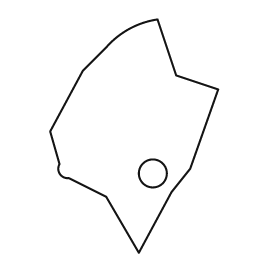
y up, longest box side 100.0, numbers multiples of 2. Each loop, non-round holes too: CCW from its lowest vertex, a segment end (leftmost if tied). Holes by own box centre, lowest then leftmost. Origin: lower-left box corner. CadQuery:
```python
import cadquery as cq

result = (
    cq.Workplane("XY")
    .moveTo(38.0, 0.0)
    .lineTo(52.0, 26.0)
    .lineTo(60.0, 36.0)
    .lineTo(72.0, 70.0)
    .lineTo(54.0, 76.0)
    .lineTo(46.0, 100.0)
    .threePointArc((34.0, 96.0), (24.0, 88.0))
    .lineTo(14.0, 78.0)
    .lineTo(0.0, 52.0)
    .lineTo(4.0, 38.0)
    .threePointArc((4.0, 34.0), (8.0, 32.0))
    .lineTo(24.0, 24.0)
    .close()
    .moveTo(44.0, 34.0)
    .circle(6.0)
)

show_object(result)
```